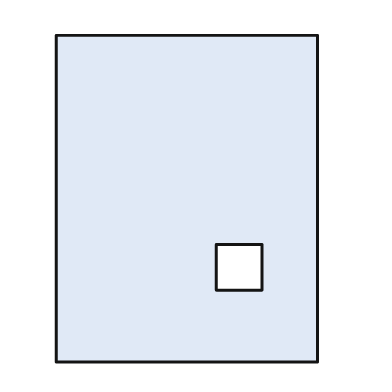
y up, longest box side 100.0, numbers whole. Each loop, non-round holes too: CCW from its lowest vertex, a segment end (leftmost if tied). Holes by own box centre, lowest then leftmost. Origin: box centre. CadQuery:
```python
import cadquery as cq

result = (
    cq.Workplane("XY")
    .moveTo(-40.0, -50.0)
    .lineTo(40.0, -50.0)
    .lineTo(40.0, 50.0)
    .lineTo(-40.0, 50.0)
    .close()
    .moveTo(9.0, -28.0)
    .lineTo(23.0, -28.0)
    .lineTo(23.0, -14.0)
    .lineTo(9.0, -14.0)
    .close()
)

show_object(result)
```